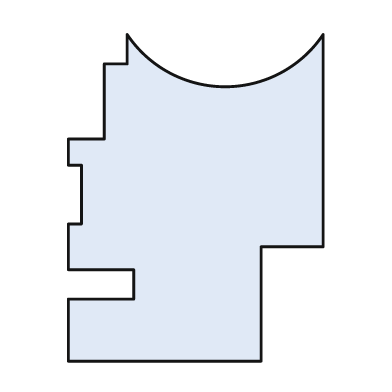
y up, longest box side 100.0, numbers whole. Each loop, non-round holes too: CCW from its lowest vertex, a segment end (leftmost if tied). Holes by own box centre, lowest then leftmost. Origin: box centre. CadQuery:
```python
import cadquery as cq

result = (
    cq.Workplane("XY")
    .moveTo(-39.0, -50.0)
    .lineTo(20.0, -50.0)
    .lineTo(20.0, -15.0)
    .lineTo(39.0, -15.0)
    .lineTo(39.0, 50.0)
    .threePointArc((9.0, 34.0), (-21.0, 50.0))
    .lineTo(-21.0, 41.0)
    .lineTo(-28.0, 41.0)
    .lineTo(-28.0, 18.0)
    .lineTo(-39.0, 18.0)
    .lineTo(-39.0, 10.0)
    .lineTo(-35.0, 10.0)
    .lineTo(-35.0, -8.0)
    .lineTo(-39.0, -8.0)
    .lineTo(-39.0, -22.0)
    .lineTo(-19.0, -22.0)
    .lineTo(-19.0, -31.0)
    .lineTo(-39.0, -31.0)
    .close()
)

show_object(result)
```